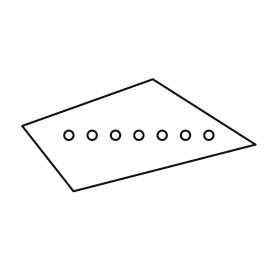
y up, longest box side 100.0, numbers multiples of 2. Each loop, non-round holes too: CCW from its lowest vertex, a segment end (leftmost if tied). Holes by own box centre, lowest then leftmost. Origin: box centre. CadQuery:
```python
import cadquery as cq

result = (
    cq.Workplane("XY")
    .moveTo(-28.0, -24.0)
    .lineTo(50.0, -4.0)
    .lineTo(6.0, 24.0)
    .lineTo(-50.0, 4.0)
    .close()
    .moveTo(-30.0, 0.0)
    .circle(2.0)
    .moveTo(-20.0, 0.0)
    .circle(2.0)
    .moveTo(-10.0, 0.0)
    .circle(2.0)
    .moveTo(0.0, 0.0)
    .circle(2.0)
    .moveTo(10.0, 0.0)
    .circle(2.0)
    .moveTo(20.0, 0.0)
    .circle(2.0)
    .moveTo(30.0, 0.0)
    .circle(2.0)
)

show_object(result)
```